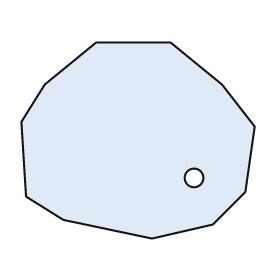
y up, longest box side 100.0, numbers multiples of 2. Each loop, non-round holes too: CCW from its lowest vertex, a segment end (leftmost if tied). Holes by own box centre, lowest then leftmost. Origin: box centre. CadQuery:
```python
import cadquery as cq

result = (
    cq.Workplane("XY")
    .moveTo(6.0, -42.0)
    .lineTo(32.0, -36.0)
    .lineTo(46.0, -22.0)
    .lineTo(50.0, 6.0)
    .lineTo(36.0, 24.0)
    .lineTo(14.0, 42.0)
    .lineTo(-18.0, 42.0)
    .lineTo(-40.0, 24.0)
    .lineTo(-50.0, 8.0)
    .lineTo(-48.0, -24.0)
    .lineTo(-32.0, -34.0)
    .close()
    .moveTo(24.0, -16.0)
    .circle(4.0)
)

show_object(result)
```